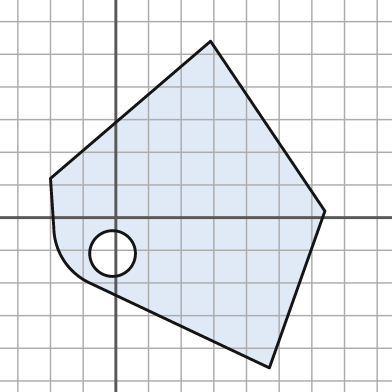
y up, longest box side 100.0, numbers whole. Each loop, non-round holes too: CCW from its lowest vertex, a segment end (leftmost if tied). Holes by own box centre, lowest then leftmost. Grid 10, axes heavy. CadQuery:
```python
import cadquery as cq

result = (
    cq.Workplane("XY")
    .moveTo(47.0, -46.0)
    .lineTo(64.0, 2.0)
    .lineTo(29.0, 54.0)
    .lineTo(-20.0, 12.0)
    .lineTo(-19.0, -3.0)
    .threePointArc((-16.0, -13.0), (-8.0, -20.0))
    .close()
    .moveTo(-1.0, -11.0)
    .circle(7.0)
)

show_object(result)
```